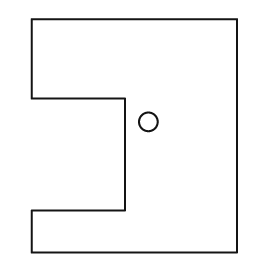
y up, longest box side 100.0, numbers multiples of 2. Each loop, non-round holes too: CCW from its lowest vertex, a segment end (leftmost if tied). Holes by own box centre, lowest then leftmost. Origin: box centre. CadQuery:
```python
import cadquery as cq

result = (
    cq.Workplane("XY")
    .moveTo(-44.0, -50.0)
    .lineTo(44.0, -50.0)
    .lineTo(44.0, 50.0)
    .lineTo(-44.0, 50.0)
    .lineTo(-44.0, 16.0)
    .lineTo(-4.0, 16.0)
    .lineTo(-4.0, -32.0)
    .lineTo(-44.0, -32.0)
    .close()
    .moveTo(6.0, 6.0)
    .circle(4.0)
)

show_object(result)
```